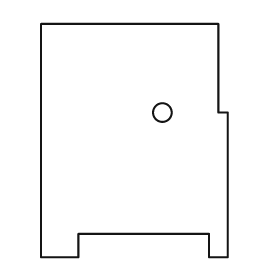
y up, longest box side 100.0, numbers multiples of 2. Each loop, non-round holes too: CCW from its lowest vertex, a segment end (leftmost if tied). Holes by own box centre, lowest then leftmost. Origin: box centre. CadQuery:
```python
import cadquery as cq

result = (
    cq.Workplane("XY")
    .moveTo(-40.0, -50.0)
    .lineTo(-24.0, -50.0)
    .lineTo(-24.0, -40.0)
    .lineTo(32.0, -40.0)
    .lineTo(32.0, -50.0)
    .lineTo(40.0, -50.0)
    .lineTo(40.0, 12.0)
    .lineTo(36.0, 12.0)
    .lineTo(36.0, 50.0)
    .lineTo(-40.0, 50.0)
    .close()
    .moveTo(12.0, 12.0)
    .circle(4.0)
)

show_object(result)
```